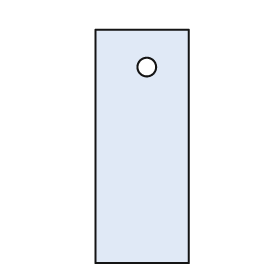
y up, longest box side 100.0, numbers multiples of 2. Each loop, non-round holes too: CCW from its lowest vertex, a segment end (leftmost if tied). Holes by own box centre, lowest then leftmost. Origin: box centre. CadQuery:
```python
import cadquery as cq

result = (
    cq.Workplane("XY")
    .moveTo(-20.0, -50.0)
    .lineTo(20.0, -50.0)
    .lineTo(20.0, 50.0)
    .lineTo(-20.0, 50.0)
    .close()
    .moveTo(2.0, 34.0)
    .circle(4.0)
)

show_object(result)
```